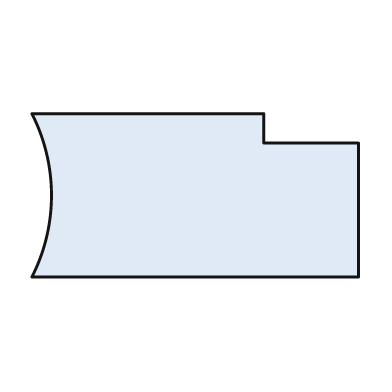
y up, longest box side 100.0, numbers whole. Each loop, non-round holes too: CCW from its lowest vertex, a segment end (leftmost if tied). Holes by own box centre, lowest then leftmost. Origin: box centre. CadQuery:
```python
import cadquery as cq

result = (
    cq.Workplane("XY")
    .moveTo(-50.0, -25.0)
    .lineTo(50.0, -25.0)
    .lineTo(50.0, 16.0)
    .lineTo(21.0, 16.0)
    .lineTo(21.0, 25.0)
    .lineTo(-50.0, 25.0)
    .threePointArc((-44.0, 0.0), (-50.0, -25.0))
    .close()
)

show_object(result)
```